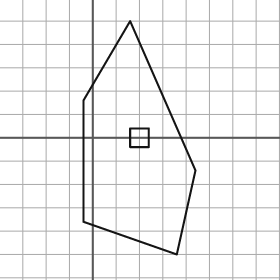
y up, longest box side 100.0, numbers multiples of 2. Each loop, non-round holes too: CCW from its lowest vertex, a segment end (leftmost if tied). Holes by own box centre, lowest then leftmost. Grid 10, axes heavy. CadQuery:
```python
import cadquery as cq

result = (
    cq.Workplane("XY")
    .moveTo(36.0, -50.0)
    .lineTo(44.0, -14.0)
    .lineTo(16.0, 50.0)
    .lineTo(-4.0, 16.0)
    .lineTo(-4.0, -36.0)
    .close()
    .moveTo(16.0, -4.0)
    .lineTo(24.0, -4.0)
    .lineTo(24.0, 4.0)
    .lineTo(16.0, 4.0)
    .close()
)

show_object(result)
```